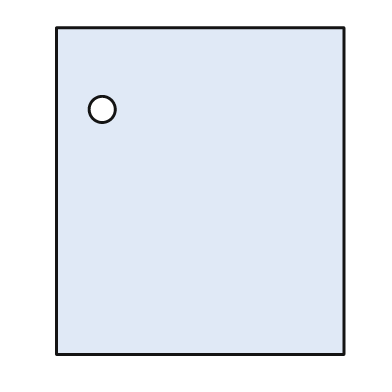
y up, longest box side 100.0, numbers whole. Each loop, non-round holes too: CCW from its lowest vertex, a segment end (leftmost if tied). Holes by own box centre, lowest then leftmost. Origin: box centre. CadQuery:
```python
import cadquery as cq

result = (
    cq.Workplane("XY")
    .moveTo(-44.0, -50.0)
    .lineTo(44.0, -50.0)
    .lineTo(44.0, 50.0)
    .lineTo(-44.0, 50.0)
    .close()
    .moveTo(-30.0, 25.0)
    .circle(4.0)
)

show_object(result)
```